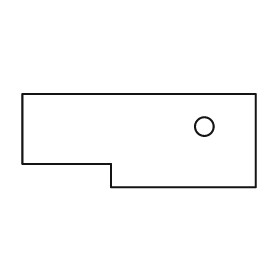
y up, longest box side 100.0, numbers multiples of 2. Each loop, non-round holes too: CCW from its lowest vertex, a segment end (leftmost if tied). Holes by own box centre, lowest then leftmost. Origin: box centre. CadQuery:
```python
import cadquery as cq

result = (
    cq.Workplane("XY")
    .moveTo(-12.0, -20.0)
    .lineTo(50.0, -20.0)
    .lineTo(50.0, 20.0)
    .lineTo(-50.0, 20.0)
    .lineTo(-50.0, -10.0)
    .lineTo(-12.0, -10.0)
    .close()
    .moveTo(28.0, 6.0)
    .circle(4.0)
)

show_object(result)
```